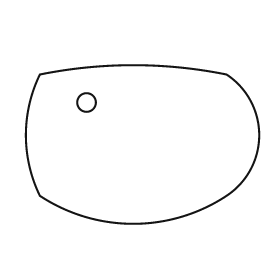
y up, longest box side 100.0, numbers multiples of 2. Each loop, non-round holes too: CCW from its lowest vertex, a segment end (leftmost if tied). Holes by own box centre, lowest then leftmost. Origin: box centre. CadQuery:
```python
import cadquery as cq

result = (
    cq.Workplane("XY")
    .moveTo(-44.0, -22.0)
    .threePointArc((-4.0, -34.0), (36.0, -22.0))
    .threePointArc((50.0, 4.0), (36.0, 30.0))
    .threePointArc((-4.0, 34.0), (-44.0, 30.0))
    .threePointArc((-50.0, 4.0), (-44.0, -22.0))
    .close()
    .moveTo(-24.0, 18.0)
    .circle(4.0)
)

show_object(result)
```